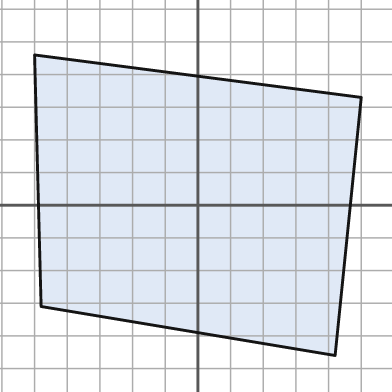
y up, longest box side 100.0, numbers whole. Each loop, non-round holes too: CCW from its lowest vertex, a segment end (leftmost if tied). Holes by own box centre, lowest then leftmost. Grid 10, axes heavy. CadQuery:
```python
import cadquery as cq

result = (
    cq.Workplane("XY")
    .moveTo(42.0, -46.0)
    .lineTo(50.0, 33.0)
    .lineTo(-50.0, 46.0)
    .lineTo(-48.0, -31.0)
    .close()
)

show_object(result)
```